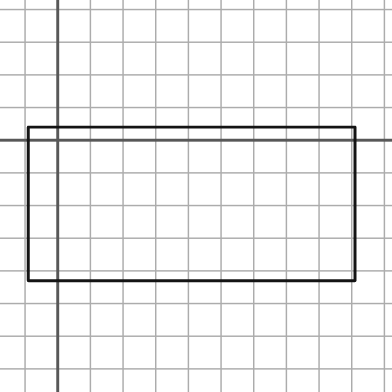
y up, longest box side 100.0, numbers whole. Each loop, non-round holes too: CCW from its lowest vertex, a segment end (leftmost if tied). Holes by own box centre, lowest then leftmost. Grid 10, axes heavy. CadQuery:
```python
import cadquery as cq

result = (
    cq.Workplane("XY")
    .moveTo(-9.0, -43.0)
    .lineTo(91.0, -43.0)
    .lineTo(91.0, 4.0)
    .lineTo(-9.0, 4.0)
    .close()
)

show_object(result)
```